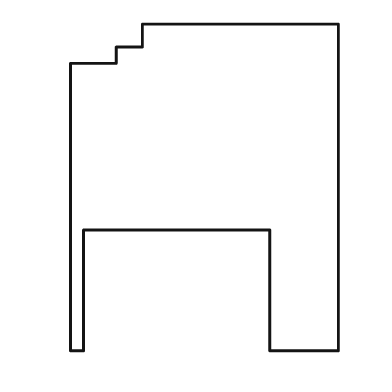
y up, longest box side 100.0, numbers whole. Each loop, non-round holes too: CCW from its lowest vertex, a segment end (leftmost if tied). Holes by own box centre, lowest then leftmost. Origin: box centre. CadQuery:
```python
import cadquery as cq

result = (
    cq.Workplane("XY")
    .moveTo(-41.0, -50.0)
    .lineTo(-37.0, -50.0)
    .lineTo(-37.0, -13.0)
    .lineTo(20.0, -13.0)
    .lineTo(20.0, -50.0)
    .lineTo(41.0, -50.0)
    .lineTo(41.0, 50.0)
    .lineTo(-19.0, 50.0)
    .lineTo(-19.0, 43.0)
    .lineTo(-27.0, 43.0)
    .lineTo(-27.0, 38.0)
    .lineTo(-41.0, 38.0)
    .close()
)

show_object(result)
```